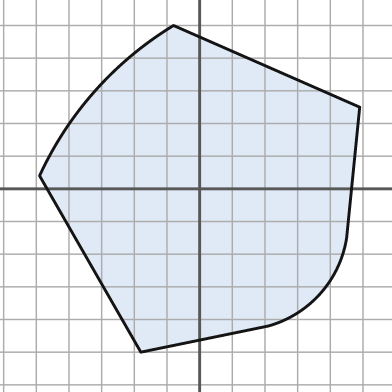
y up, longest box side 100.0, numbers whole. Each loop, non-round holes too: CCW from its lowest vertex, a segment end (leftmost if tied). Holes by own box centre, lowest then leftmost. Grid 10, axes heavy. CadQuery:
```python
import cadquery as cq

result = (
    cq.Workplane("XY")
    .moveTo(-18.0, -50.0)
    .lineTo(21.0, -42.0)
    .threePointArc((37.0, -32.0), (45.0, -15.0))
    .lineTo(49.0, 25.0)
    .lineTo(-8.0, 50.0)
    .threePointArc((-32.0, 30.0), (-49.0, 4.0))
    .close()
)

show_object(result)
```